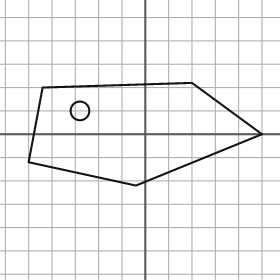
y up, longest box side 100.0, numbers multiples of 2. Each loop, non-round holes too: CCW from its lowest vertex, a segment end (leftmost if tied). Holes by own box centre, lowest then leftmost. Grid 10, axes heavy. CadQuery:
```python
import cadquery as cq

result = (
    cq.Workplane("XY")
    .moveTo(-4.0, -22.0)
    .lineTo(50.0, 0.0)
    .lineTo(20.0, 22.0)
    .lineTo(-44.0, 20.0)
    .lineTo(-50.0, -12.0)
    .close()
    .moveTo(-28.0, 10.0)
    .circle(4.0)
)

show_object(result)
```